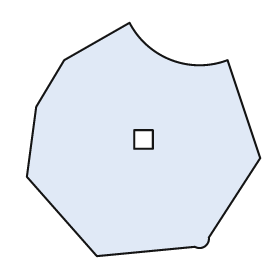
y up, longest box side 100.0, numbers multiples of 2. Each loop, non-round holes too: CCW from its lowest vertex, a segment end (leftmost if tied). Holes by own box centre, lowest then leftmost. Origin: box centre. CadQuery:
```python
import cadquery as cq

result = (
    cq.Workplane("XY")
    .moveTo(-20.0, -50.0)
    .lineTo(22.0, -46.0)
    .threePointArc((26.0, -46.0), (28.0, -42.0))
    .lineTo(50.0, -8.0)
    .lineTo(36.0, 34.0)
    .threePointArc((12.0, 34.0), (-6.0, 50.0))
    .lineTo(-34.0, 34.0)
    .lineTo(-46.0, 14.0)
    .lineTo(-50.0, -16.0)
    .close()
    .moveTo(-4.0, -4.0)
    .lineTo(4.0, -4.0)
    .lineTo(4.0, 4.0)
    .lineTo(-4.0, 4.0)
    .close()
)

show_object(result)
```